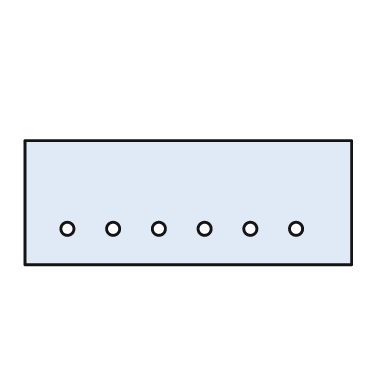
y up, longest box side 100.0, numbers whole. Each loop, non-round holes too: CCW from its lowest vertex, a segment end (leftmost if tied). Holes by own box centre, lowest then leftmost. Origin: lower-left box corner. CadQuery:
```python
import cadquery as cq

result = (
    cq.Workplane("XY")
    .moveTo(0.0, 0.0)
    .lineTo(100.0, 0.0)
    .lineTo(100.0, 38.0)
    .lineTo(0.0, 38.0)
    .close()
    .moveTo(13.0, 11.0)
    .circle(2.0)
    .moveTo(27.0, 11.0)
    .circle(2.0)
    .moveTo(41.0, 11.0)
    .circle(2.0)
    .moveTo(55.0, 11.0)
    .circle(2.0)
    .moveTo(69.0, 11.0)
    .circle(2.0)
    .moveTo(83.0, 11.0)
    .circle(2.0)
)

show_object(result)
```